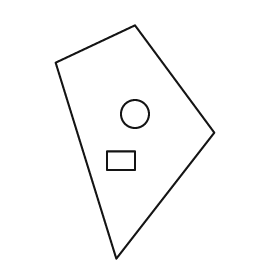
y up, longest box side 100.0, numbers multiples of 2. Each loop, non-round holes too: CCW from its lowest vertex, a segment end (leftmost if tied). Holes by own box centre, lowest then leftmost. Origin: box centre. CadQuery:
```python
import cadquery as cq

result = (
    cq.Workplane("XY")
    .moveTo(-8.0, -50.0)
    .lineTo(34.0, 4.0)
    .lineTo(0.0, 50.0)
    .lineTo(-34.0, 34.0)
    .close()
    .moveTo(-12.0, -12.0)
    .lineTo(0.0, -12.0)
    .lineTo(0.0, -4.0)
    .lineTo(-12.0, -4.0)
    .close()
    .moveTo(0.0, 12.0)
    .circle(6.0)
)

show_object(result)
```